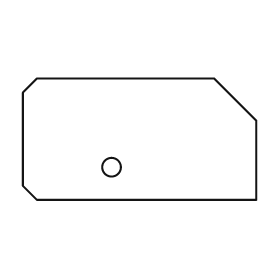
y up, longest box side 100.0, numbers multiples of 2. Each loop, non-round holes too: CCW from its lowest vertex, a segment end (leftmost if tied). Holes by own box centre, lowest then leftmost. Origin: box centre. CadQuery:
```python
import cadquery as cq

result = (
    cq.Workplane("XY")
    .moveTo(-44.0, -26.0)
    .lineTo(50.0, -26.0)
    .lineTo(50.0, 8.0)
    .lineTo(32.0, 26.0)
    .lineTo(-44.0, 26.0)
    .lineTo(-50.0, 20.0)
    .lineTo(-50.0, -20.0)
    .close()
    .moveTo(-12.0, -12.0)
    .circle(4.0)
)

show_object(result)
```